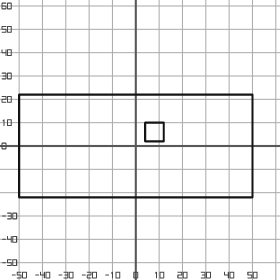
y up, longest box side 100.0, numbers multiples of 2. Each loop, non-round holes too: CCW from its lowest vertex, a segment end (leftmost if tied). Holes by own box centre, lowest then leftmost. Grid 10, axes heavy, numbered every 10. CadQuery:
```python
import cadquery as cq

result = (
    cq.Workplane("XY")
    .moveTo(-50.0, -22.0)
    .lineTo(50.0, -22.0)
    .lineTo(50.0, 22.0)
    .lineTo(-50.0, 22.0)
    .close()
    .moveTo(4.0, 2.0)
    .lineTo(12.0, 2.0)
    .lineTo(12.0, 10.0)
    .lineTo(4.0, 10.0)
    .close()
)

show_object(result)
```